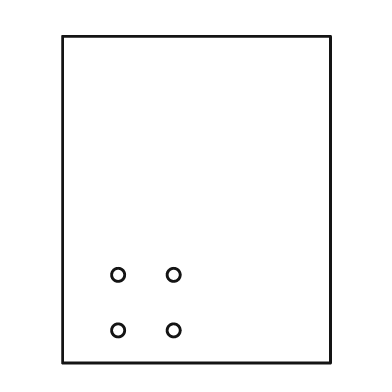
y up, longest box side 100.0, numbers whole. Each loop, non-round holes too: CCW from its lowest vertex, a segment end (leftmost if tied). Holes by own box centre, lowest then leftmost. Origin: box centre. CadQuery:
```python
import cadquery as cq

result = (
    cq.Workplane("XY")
    .moveTo(-41.0, -50.0)
    .lineTo(41.0, -50.0)
    .lineTo(41.0, 50.0)
    .lineTo(-41.0, 50.0)
    .close()
    .moveTo(-24.0, -40.0)
    .circle(2.0)
    .moveTo(-7.0, -40.0)
    .circle(2.0)
    .moveTo(-24.0, -23.0)
    .circle(2.0)
    .moveTo(-7.0, -23.0)
    .circle(2.0)
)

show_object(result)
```